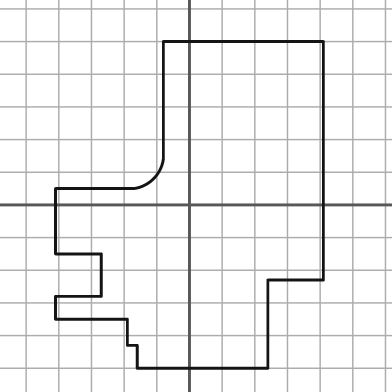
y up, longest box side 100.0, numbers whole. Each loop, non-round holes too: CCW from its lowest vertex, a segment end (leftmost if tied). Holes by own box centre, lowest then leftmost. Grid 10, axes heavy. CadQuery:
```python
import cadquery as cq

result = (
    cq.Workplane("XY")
    .moveTo(-16.0, -50.0)
    .lineTo(24.0, -50.0)
    .lineTo(24.0, -23.0)
    .lineTo(41.0, -23.0)
    .lineTo(41.0, 50.0)
    .lineTo(-8.0, 50.0)
    .lineTo(-8.0, 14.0)
    .threePointArc((-11.0, 8.0), (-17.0, 5.0))
    .lineTo(-41.0, 5.0)
    .lineTo(-41.0, -15.0)
    .lineTo(-27.0, -15.0)
    .lineTo(-27.0, -28.0)
    .lineTo(-41.0, -28.0)
    .lineTo(-41.0, -35.0)
    .lineTo(-19.0, -35.0)
    .lineTo(-19.0, -43.0)
    .lineTo(-16.0, -43.0)
    .close()
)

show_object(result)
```